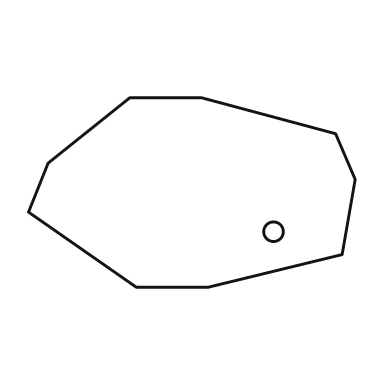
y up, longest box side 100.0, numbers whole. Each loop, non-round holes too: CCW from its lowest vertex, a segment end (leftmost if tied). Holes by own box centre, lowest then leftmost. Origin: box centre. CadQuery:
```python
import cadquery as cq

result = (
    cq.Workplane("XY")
    .moveTo(-17.0, -29.0)
    .lineTo(5.0, -29.0)
    .lineTo(46.0, -19.0)
    .lineTo(50.0, 4.0)
    .lineTo(44.0, 18.0)
    .lineTo(3.0, 29.0)
    .lineTo(-19.0, 29.0)
    .lineTo(-44.0, 9.0)
    .lineTo(-50.0, -6.0)
    .close()
    .moveTo(25.0, -12.0)
    .circle(3.0)
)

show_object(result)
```